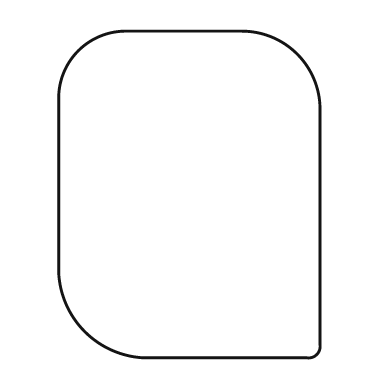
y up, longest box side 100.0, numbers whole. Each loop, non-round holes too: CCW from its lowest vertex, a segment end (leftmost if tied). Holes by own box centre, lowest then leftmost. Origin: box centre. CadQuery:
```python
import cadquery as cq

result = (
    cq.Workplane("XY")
    .moveTo(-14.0, -50.0)
    .lineTo(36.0, -50.0)
    .threePointArc((39.0, -49.0), (40.0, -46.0))
    .lineTo(40.0, 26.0)
    .threePointArc((33.0, 43.0), (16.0, 50.0))
    .lineTo(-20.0, 50.0)
    .threePointArc((-34.0, 44.0), (-40.0, 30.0))
    .lineTo(-40.0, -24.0)
    .threePointArc((-32.0, -42.0), (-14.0, -50.0))
    .close()
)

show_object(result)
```